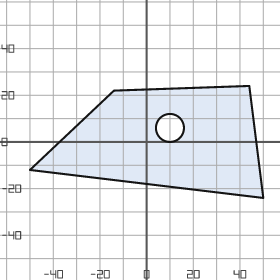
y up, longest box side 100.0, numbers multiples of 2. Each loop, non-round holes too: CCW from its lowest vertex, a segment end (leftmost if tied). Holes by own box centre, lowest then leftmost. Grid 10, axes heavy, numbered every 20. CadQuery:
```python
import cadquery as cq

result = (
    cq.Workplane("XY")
    .moveTo(50.0, -24.0)
    .lineTo(44.0, 24.0)
    .lineTo(-14.0, 22.0)
    .lineTo(-50.0, -12.0)
    .close()
    .moveTo(10.0, 6.0)
    .circle(6.0)
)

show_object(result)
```